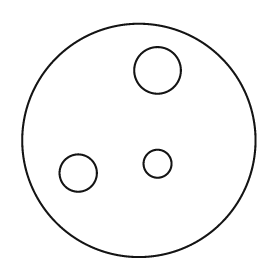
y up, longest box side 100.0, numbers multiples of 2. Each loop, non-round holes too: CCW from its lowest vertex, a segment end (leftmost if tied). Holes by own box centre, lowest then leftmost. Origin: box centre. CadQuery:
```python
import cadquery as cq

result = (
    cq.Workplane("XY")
    .moveTo(0.0, 0.0)
    .circle(50.0)
    .moveTo(-26.0, -14.0)
    .circle(8.0)
    .moveTo(8.0, -10.0)
    .circle(6.0)
    .moveTo(8.0, 30.0)
    .circle(10.0)
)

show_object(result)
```